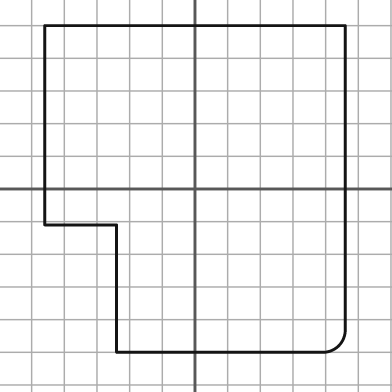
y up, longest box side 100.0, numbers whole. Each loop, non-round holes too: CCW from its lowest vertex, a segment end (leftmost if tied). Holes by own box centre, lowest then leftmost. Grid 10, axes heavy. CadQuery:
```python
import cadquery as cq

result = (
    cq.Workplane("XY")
    .moveTo(-24.0, -50.0)
    .lineTo(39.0, -50.0)
    .threePointArc((44.0, -48.0), (46.0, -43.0))
    .lineTo(46.0, 50.0)
    .lineTo(-46.0, 50.0)
    .lineTo(-46.0, -11.0)
    .lineTo(-24.0, -11.0)
    .close()
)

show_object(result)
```